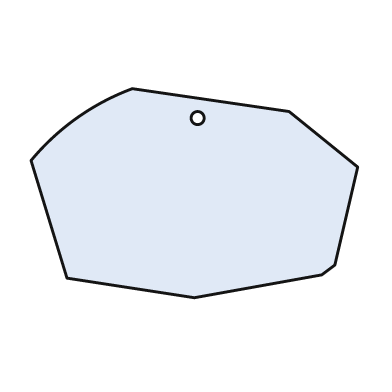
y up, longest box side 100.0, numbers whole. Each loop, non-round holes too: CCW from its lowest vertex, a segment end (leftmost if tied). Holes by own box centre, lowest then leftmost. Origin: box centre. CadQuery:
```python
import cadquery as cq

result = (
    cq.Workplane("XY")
    .moveTo(0.0, -32.0)
    .lineTo(39.0, -25.0)
    .lineTo(43.0, -22.0)
    .lineTo(50.0, 8.0)
    .lineTo(29.0, 25.0)
    .lineTo(-19.0, 32.0)
    .threePointArc((-36.0, 23.0), (-50.0, 10.0))
    .lineTo(-39.0, -26.0)
    .close()
    .moveTo(1.0, 23.0)
    .circle(2.0)
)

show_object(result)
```